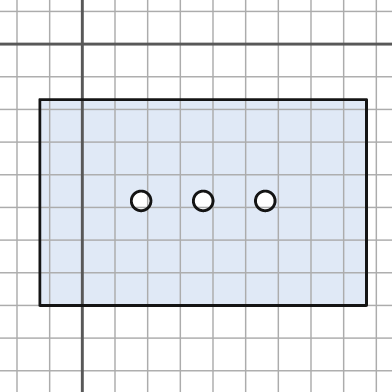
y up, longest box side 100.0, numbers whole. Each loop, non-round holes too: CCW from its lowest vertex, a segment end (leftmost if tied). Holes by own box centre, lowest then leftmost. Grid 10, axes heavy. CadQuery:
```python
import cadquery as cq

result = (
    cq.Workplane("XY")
    .moveTo(-13.0, -80.0)
    .lineTo(87.0, -80.0)
    .lineTo(87.0, -17.0)
    .lineTo(-13.0, -17.0)
    .close()
    .moveTo(18.0, -48.0)
    .circle(3.0)
    .moveTo(37.0, -48.0)
    .circle(3.0)
    .moveTo(56.0, -48.0)
    .circle(3.0)
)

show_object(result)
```